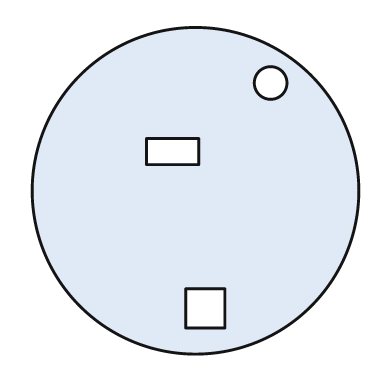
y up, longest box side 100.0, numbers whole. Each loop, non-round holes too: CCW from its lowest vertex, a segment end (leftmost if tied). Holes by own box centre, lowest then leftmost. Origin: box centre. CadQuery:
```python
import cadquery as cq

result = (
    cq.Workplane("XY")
    .moveTo(0.0, 0.0)
    .circle(50.0)
    .moveTo(-3.0, -42.0)
    .lineTo(9.0, -42.0)
    .lineTo(9.0, -30.0)
    .lineTo(-3.0, -30.0)
    .close()
    .moveTo(-15.0, 8.0)
    .lineTo(1.0, 8.0)
    .lineTo(1.0, 16.0)
    .lineTo(-15.0, 16.0)
    .close()
    .moveTo(23.0, 33.0)
    .circle(5.0)
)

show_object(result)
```